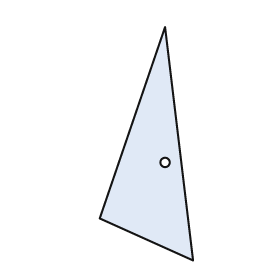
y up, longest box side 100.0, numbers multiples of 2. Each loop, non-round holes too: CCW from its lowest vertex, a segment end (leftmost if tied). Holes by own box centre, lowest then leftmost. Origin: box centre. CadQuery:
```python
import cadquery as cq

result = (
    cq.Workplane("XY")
    .moveTo(20.0, -50.0)
    .lineTo(8.0, 50.0)
    .lineTo(-20.0, -32.0)
    .close()
    .moveTo(8.0, -8.0)
    .circle(2.0)
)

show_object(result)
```